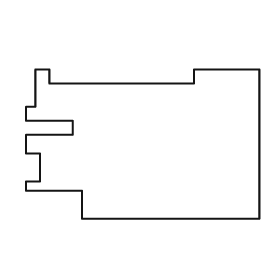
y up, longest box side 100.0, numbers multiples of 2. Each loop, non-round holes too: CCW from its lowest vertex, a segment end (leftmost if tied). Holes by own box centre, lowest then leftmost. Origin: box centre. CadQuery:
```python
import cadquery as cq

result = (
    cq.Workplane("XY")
    .moveTo(-26.0, -32.0)
    .lineTo(50.0, -32.0)
    .lineTo(50.0, 32.0)
    .lineTo(22.0, 32.0)
    .lineTo(22.0, 26.0)
    .lineTo(-40.0, 26.0)
    .lineTo(-40.0, 32.0)
    .lineTo(-46.0, 32.0)
    .lineTo(-46.0, 16.0)
    .lineTo(-50.0, 16.0)
    .lineTo(-50.0, 10.0)
    .lineTo(-30.0, 10.0)
    .lineTo(-30.0, 4.0)
    .lineTo(-50.0, 4.0)
    .lineTo(-50.0, -4.0)
    .lineTo(-44.0, -4.0)
    .lineTo(-44.0, -16.0)
    .lineTo(-50.0, -16.0)
    .lineTo(-50.0, -20.0)
    .lineTo(-26.0, -20.0)
    .close()
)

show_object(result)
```